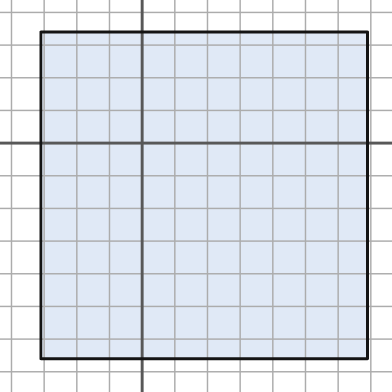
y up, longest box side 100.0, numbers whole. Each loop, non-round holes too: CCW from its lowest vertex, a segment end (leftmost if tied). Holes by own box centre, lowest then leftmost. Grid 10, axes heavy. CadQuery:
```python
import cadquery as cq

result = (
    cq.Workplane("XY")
    .moveTo(-31.0, -66.0)
    .lineTo(69.0, -66.0)
    .lineTo(69.0, 34.0)
    .lineTo(-31.0, 34.0)
    .close()
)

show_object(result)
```